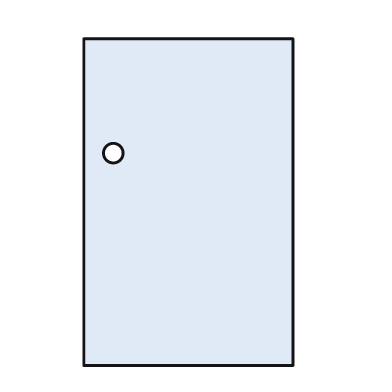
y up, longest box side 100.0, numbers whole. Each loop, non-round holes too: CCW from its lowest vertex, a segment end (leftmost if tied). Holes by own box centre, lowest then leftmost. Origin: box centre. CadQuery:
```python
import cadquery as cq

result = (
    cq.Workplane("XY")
    .moveTo(-32.0, -50.0)
    .lineTo(32.0, -50.0)
    .lineTo(32.0, 50.0)
    .lineTo(-32.0, 50.0)
    .close()
    .moveTo(-23.0, 15.0)
    .circle(3.0)
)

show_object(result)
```